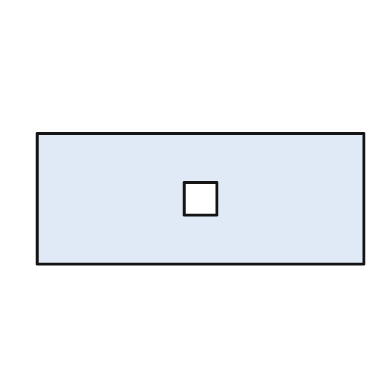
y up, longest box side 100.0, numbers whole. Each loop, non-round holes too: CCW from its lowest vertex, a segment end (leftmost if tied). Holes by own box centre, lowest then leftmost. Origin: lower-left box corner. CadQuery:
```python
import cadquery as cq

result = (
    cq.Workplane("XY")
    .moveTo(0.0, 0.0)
    .lineTo(100.0, 0.0)
    .lineTo(100.0, 40.0)
    .lineTo(0.0, 40.0)
    .close()
    .moveTo(45.0, 15.0)
    .lineTo(55.0, 15.0)
    .lineTo(55.0, 25.0)
    .lineTo(45.0, 25.0)
    .close()
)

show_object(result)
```